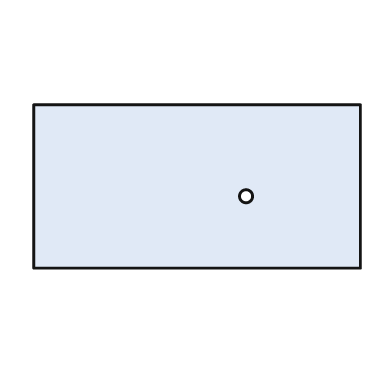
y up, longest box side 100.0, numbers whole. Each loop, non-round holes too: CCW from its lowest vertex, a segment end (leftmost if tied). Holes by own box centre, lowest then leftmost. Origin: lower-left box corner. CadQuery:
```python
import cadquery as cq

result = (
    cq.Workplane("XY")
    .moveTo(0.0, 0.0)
    .lineTo(100.0, 0.0)
    .lineTo(100.0, 50.0)
    .lineTo(0.0, 50.0)
    .close()
    .moveTo(65.0, 22.0)
    .circle(2.0)
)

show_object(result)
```